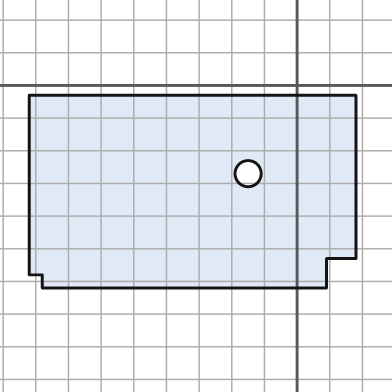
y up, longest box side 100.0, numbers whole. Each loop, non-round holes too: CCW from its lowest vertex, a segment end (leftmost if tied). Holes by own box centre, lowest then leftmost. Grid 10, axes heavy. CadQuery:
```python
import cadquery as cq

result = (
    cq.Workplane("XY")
    .moveTo(-78.0, -62.0)
    .lineTo(9.0, -62.0)
    .lineTo(9.0, -53.0)
    .lineTo(18.0, -53.0)
    .lineTo(18.0, -3.0)
    .lineTo(-82.0, -3.0)
    .lineTo(-82.0, -58.0)
    .lineTo(-78.0, -58.0)
    .close()
    .moveTo(-15.0, -27.0)
    .circle(4.0)
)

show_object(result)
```